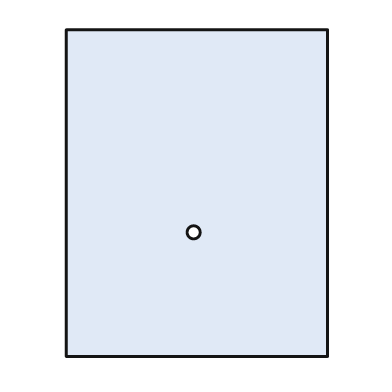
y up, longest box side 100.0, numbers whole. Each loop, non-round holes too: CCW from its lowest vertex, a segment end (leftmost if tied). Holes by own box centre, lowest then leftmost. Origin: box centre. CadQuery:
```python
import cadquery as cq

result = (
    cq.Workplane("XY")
    .moveTo(-40.0, -50.0)
    .lineTo(40.0, -50.0)
    .lineTo(40.0, 50.0)
    .lineTo(-40.0, 50.0)
    .close()
    .moveTo(-1.0, -12.0)
    .circle(2.0)
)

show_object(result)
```